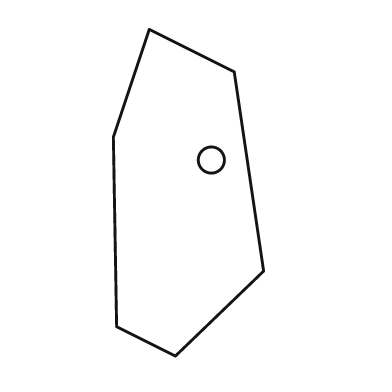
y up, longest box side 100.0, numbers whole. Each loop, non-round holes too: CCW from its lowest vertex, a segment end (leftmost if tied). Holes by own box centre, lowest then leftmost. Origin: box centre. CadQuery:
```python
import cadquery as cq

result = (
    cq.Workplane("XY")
    .moveTo(-4.0, -50.0)
    .lineTo(23.0, -24.0)
    .lineTo(14.0, 37.0)
    .lineTo(-12.0, 50.0)
    .lineTo(-23.0, 17.0)
    .lineTo(-22.0, -41.0)
    .close()
    .moveTo(7.0, 10.0)
    .circle(4.0)
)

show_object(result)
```